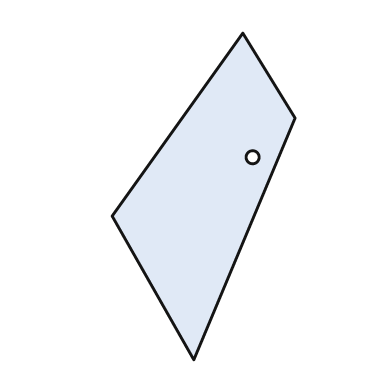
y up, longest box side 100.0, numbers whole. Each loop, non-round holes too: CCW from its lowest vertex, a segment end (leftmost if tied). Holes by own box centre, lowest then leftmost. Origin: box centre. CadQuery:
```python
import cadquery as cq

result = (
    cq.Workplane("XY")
    .moveTo(-3.0, -50.0)
    .lineTo(28.0, 24.0)
    .lineTo(12.0, 50.0)
    .lineTo(-28.0, -6.0)
    .close()
    .moveTo(15.0, 12.0)
    .circle(2.0)
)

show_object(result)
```